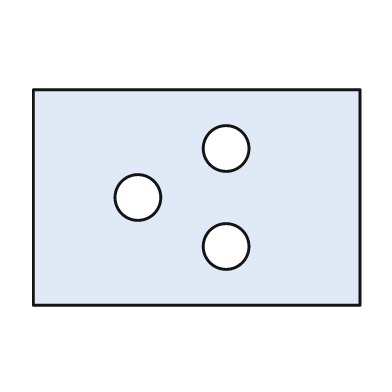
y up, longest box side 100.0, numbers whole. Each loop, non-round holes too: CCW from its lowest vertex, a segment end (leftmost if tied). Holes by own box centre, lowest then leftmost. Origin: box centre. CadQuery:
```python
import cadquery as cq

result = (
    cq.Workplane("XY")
    .moveTo(-50.0, -33.0)
    .lineTo(50.0, -33.0)
    .lineTo(50.0, 33.0)
    .lineTo(-50.0, 33.0)
    .close()
    .moveTo(9.0, -15.0)
    .circle(7.0)
    .moveTo(-18.0, 0.0)
    .circle(7.0)
    .moveTo(9.0, 15.0)
    .circle(7.0)
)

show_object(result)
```